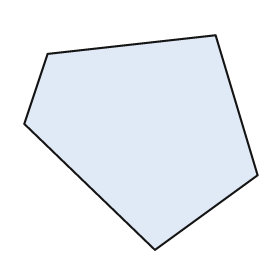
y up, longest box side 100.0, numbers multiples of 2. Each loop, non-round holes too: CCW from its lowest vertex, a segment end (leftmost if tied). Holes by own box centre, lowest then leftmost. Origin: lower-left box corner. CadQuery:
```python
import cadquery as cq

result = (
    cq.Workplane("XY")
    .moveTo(56.0, 0.0)
    .lineTo(100.0, 32.0)
    .lineTo(82.0, 92.0)
    .lineTo(10.0, 84.0)
    .lineTo(0.0, 54.0)
    .close()
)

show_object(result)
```